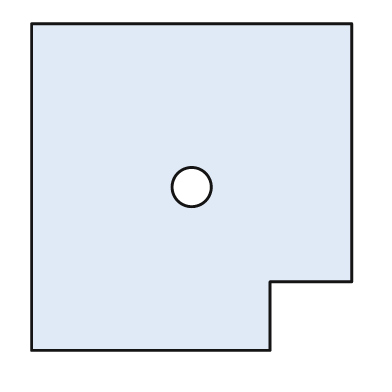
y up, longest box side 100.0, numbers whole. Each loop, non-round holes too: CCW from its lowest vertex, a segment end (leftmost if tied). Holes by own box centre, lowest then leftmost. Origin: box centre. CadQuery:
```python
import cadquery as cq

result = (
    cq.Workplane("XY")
    .moveTo(-49.0, -50.0)
    .lineTo(24.0, -50.0)
    .lineTo(24.0, -29.0)
    .lineTo(49.0, -29.0)
    .lineTo(49.0, 50.0)
    .lineTo(-49.0, 50.0)
    .close()
    .moveTo(0.0, 0.0)
    .circle(6.0)
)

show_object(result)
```